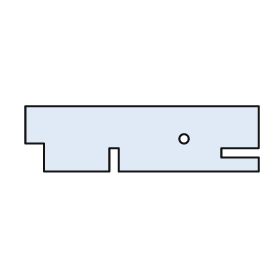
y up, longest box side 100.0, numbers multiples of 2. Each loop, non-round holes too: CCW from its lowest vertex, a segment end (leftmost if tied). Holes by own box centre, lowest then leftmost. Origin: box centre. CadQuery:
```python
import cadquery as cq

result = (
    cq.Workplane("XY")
    .moveTo(-42.0, -14.0)
    .lineTo(-14.0, -14.0)
    .lineTo(-14.0, -4.0)
    .lineTo(-10.0, -4.0)
    .lineTo(-10.0, -14.0)
    .lineTo(50.0, -14.0)
    .lineTo(50.0, -8.0)
    .lineTo(34.0, -8.0)
    .lineTo(34.0, -4.0)
    .lineTo(50.0, -4.0)
    .lineTo(50.0, 14.0)
    .lineTo(-50.0, 14.0)
    .lineTo(-50.0, -2.0)
    .lineTo(-42.0, -2.0)
    .close()
    .moveTo(18.0, 0.0)
    .circle(2.0)
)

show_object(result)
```